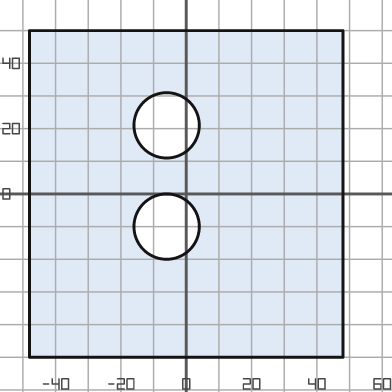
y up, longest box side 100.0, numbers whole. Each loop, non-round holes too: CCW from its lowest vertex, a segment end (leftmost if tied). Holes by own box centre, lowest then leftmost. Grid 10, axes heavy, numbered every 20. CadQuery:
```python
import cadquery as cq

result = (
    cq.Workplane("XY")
    .moveTo(-48.0, -50.0)
    .lineTo(48.0, -50.0)
    .lineTo(48.0, 50.0)
    .lineTo(-48.0, 50.0)
    .close()
    .moveTo(-6.0, -10.0)
    .circle(10.0)
    .moveTo(-6.0, 21.0)
    .circle(10.0)
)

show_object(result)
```